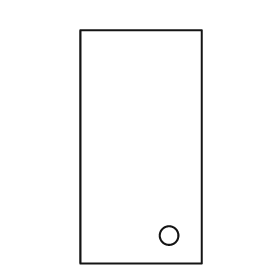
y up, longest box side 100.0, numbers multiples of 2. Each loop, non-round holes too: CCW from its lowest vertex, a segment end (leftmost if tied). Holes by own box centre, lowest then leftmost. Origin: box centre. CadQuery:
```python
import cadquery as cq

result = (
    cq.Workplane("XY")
    .moveTo(-26.0, -50.0)
    .lineTo(26.0, -50.0)
    .lineTo(26.0, 50.0)
    .lineTo(-26.0, 50.0)
    .close()
    .moveTo(12.0, -38.0)
    .circle(4.0)
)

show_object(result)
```